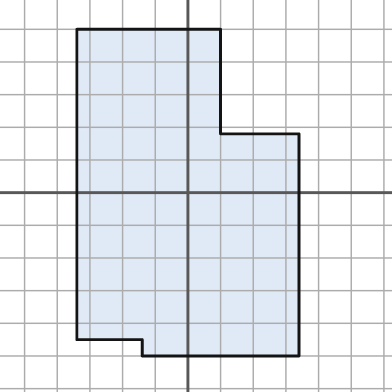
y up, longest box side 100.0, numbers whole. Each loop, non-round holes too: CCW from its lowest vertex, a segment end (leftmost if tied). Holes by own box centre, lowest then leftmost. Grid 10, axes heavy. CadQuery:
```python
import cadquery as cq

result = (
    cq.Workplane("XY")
    .moveTo(-14.0, -50.0)
    .lineTo(34.0, -50.0)
    .lineTo(34.0, 18.0)
    .lineTo(10.0, 18.0)
    .lineTo(10.0, 50.0)
    .lineTo(-34.0, 50.0)
    .lineTo(-34.0, -45.0)
    .lineTo(-14.0, -45.0)
    .close()
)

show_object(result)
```